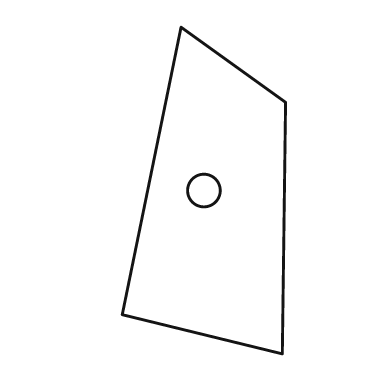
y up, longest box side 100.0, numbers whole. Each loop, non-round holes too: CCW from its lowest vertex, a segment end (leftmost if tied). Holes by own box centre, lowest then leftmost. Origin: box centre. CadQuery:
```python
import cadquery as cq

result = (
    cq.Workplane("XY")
    .moveTo(24.0, -50.0)
    .lineTo(25.0, 27.0)
    .lineTo(-7.0, 50.0)
    .lineTo(-25.0, -38.0)
    .close()
    .moveTo(0.0, 0.0)
    .circle(5.0)
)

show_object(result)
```